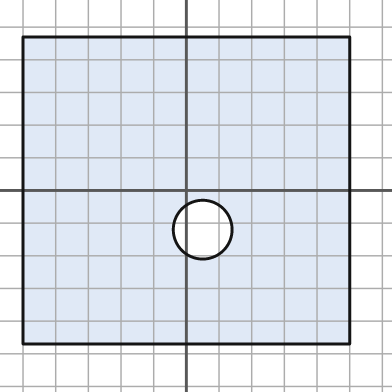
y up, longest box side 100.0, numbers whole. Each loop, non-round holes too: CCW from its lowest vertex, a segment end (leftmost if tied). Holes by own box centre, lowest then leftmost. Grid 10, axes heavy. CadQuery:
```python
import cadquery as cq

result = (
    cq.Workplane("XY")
    .moveTo(-50.0, -47.0)
    .lineTo(50.0, -47.0)
    .lineTo(50.0, 47.0)
    .lineTo(-50.0, 47.0)
    .close()
    .moveTo(5.0, -12.0)
    .circle(9.0)
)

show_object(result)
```